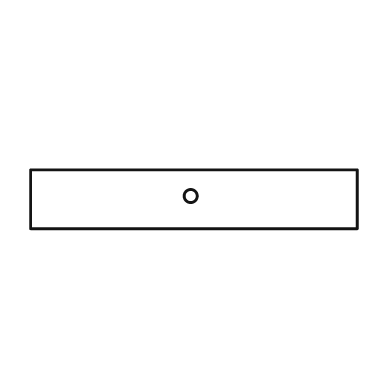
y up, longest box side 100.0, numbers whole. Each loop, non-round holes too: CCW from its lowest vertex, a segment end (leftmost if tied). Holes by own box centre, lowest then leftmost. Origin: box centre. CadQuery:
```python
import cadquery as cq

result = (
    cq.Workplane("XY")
    .moveTo(-50.0, -9.0)
    .lineTo(50.0, -9.0)
    .lineTo(50.0, 9.0)
    .lineTo(-50.0, 9.0)
    .close()
    .moveTo(-1.0, 1.0)
    .circle(2.0)
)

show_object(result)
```